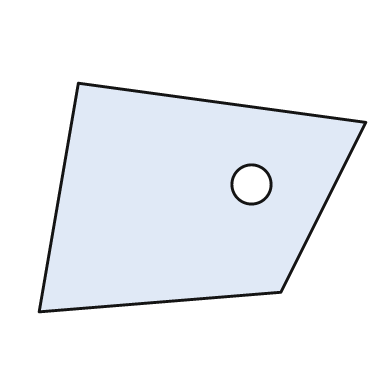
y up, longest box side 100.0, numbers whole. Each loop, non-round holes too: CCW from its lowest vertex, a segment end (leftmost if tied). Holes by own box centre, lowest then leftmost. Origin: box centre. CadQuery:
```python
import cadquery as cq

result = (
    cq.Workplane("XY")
    .moveTo(-50.0, -35.0)
    .lineTo(24.0, -29.0)
    .lineTo(50.0, 23.0)
    .lineTo(-38.0, 35.0)
    .close()
    .moveTo(15.0, 4.0)
    .circle(6.0)
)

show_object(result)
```